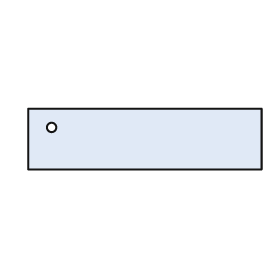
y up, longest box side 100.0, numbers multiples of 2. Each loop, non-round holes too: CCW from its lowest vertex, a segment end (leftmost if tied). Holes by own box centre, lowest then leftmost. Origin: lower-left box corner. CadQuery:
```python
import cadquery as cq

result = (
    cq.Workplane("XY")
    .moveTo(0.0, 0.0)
    .lineTo(100.0, 0.0)
    .lineTo(100.0, 26.0)
    .lineTo(0.0, 26.0)
    .close()
    .moveTo(10.0, 18.0)
    .circle(2.0)
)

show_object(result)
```